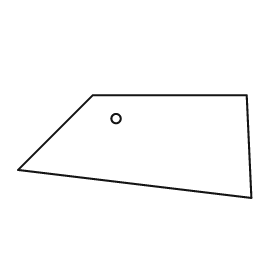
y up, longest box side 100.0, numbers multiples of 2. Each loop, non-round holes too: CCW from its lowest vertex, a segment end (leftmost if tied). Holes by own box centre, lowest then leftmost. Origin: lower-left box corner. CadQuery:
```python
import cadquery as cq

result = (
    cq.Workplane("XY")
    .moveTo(100.0, 0.0)
    .lineTo(98.0, 44.0)
    .lineTo(32.0, 44.0)
    .lineTo(0.0, 12.0)
    .close()
    .moveTo(42.0, 34.0)
    .circle(2.0)
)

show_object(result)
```